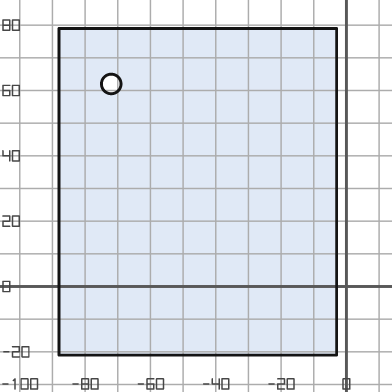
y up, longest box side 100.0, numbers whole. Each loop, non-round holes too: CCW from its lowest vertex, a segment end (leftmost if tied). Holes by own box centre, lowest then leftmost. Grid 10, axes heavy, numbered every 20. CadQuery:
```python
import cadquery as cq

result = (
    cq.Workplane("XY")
    .moveTo(-88.0, -21.0)
    .lineTo(-3.0, -21.0)
    .lineTo(-3.0, 79.0)
    .lineTo(-88.0, 79.0)
    .close()
    .moveTo(-72.0, 62.0)
    .circle(3.0)
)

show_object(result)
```